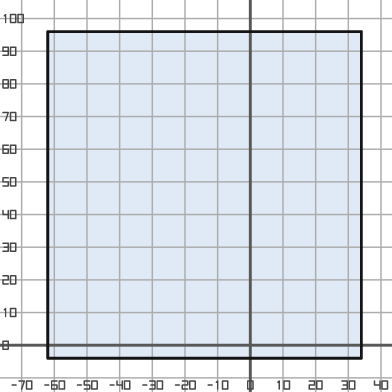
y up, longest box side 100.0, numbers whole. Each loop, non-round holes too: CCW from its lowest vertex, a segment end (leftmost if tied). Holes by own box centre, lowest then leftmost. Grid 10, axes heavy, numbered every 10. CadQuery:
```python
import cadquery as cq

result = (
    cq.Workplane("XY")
    .moveTo(-62.0, -4.0)
    .lineTo(34.0, -4.0)
    .lineTo(34.0, 96.0)
    .lineTo(-62.0, 96.0)
    .close()
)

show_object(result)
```